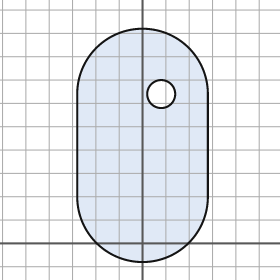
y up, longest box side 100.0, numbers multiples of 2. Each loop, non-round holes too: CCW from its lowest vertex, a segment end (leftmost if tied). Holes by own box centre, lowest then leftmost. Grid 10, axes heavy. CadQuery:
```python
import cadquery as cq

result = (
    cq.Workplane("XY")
    .moveTo(-28.0, 20.0)
    .threePointArc((0.0, -8.0), (28.0, 20.0))
    .lineTo(28.0, 64.0)
    .threePointArc((0.0, 92.0), (-28.0, 64.0))
    .close()
    .moveTo(8.0, 64.0)
    .circle(6.0)
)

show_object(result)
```